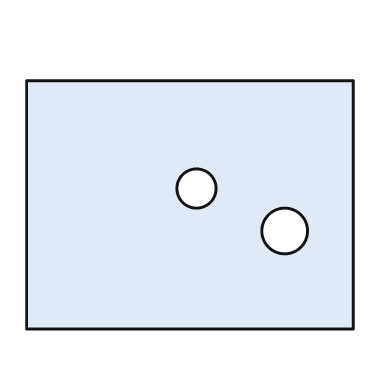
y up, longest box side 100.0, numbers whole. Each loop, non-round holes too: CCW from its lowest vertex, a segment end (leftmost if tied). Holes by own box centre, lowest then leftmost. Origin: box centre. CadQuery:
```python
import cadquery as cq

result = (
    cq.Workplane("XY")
    .moveTo(-50.0, -38.0)
    .lineTo(50.0, -38.0)
    .lineTo(50.0, 38.0)
    .lineTo(-50.0, 38.0)
    .close()
    .moveTo(29.0, -8.0)
    .circle(7.0)
    .moveTo(2.0, 5.0)
    .circle(6.0)
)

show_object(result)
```